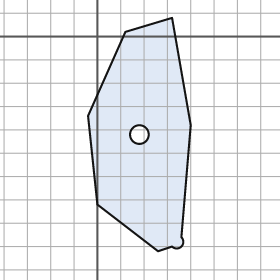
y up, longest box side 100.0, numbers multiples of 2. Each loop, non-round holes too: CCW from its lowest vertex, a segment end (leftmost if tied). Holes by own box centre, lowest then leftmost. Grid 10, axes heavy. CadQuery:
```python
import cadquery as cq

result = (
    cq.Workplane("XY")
    .moveTo(26.0, -92.0)
    .lineTo(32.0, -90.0)
    .threePointArc((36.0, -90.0), (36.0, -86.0))
    .lineTo(40.0, -38.0)
    .lineTo(32.0, 8.0)
    .lineTo(12.0, 2.0)
    .lineTo(-4.0, -34.0)
    .lineTo(0.0, -72.0)
    .close()
    .moveTo(18.0, -42.0)
    .circle(4.0)
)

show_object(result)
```